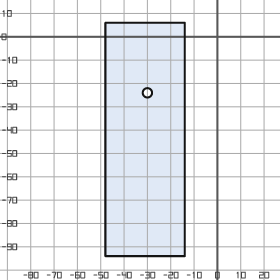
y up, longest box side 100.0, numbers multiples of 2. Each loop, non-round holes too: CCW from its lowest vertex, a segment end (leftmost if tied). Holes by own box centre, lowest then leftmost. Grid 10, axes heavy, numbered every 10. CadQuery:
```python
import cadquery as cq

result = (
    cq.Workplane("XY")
    .moveTo(-48.0, -94.0)
    .lineTo(-14.0, -94.0)
    .lineTo(-14.0, 6.0)
    .lineTo(-48.0, 6.0)
    .close()
    .moveTo(-30.0, -24.0)
    .circle(2.0)
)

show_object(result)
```